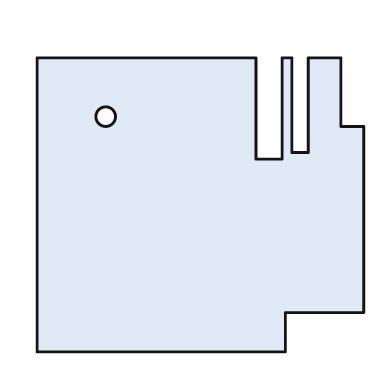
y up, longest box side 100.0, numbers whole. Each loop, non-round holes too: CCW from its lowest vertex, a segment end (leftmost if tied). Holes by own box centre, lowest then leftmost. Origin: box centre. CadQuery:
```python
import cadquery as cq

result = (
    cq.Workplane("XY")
    .moveTo(-50.0, -45.0)
    .lineTo(26.0, -45.0)
    .lineTo(26.0, -33.0)
    .lineTo(50.0, -33.0)
    .lineTo(50.0, 24.0)
    .lineTo(43.0, 24.0)
    .lineTo(43.0, 45.0)
    .lineTo(33.0, 45.0)
    .lineTo(33.0, 16.0)
    .lineTo(28.0, 16.0)
    .lineTo(28.0, 45.0)
    .lineTo(25.0, 45.0)
    .lineTo(25.0, 14.0)
    .lineTo(17.0, 14.0)
    .lineTo(17.0, 45.0)
    .lineTo(-50.0, 45.0)
    .close()
    .moveTo(-29.0, 27.0)
    .circle(3.0)
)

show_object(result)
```